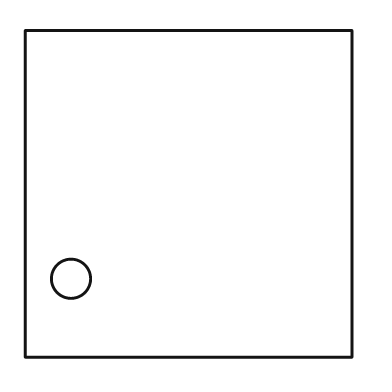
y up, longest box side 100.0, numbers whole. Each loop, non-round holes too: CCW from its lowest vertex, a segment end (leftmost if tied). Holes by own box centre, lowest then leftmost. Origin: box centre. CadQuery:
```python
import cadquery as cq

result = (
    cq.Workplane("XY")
    .moveTo(-50.0, -50.0)
    .lineTo(50.0, -50.0)
    .lineTo(50.0, 50.0)
    .lineTo(-50.0, 50.0)
    .close()
    .moveTo(-36.0, -26.0)
    .circle(6.0)
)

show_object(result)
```